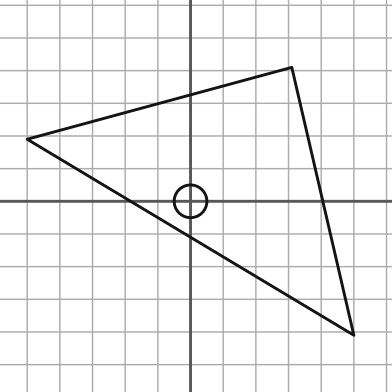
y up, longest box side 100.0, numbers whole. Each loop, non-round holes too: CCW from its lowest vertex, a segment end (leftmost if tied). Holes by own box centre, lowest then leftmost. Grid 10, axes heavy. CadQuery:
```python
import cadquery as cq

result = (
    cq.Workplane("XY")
    .moveTo(50.0, -41.0)
    .lineTo(31.0, 41.0)
    .lineTo(-50.0, 19.0)
    .close()
    .moveTo(0.0, 0.0)
    .circle(5.0)
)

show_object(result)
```